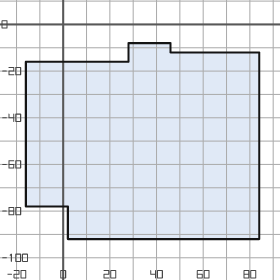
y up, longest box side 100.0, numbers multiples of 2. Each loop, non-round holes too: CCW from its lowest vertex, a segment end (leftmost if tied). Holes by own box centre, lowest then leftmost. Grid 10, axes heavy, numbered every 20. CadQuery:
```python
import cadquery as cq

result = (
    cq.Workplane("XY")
    .moveTo(2.0, -92.0)
    .lineTo(84.0, -92.0)
    .lineTo(84.0, -12.0)
    .lineTo(46.0, -12.0)
    .lineTo(46.0, -8.0)
    .lineTo(28.0, -8.0)
    .lineTo(28.0, -16.0)
    .lineTo(-16.0, -16.0)
    .lineTo(-16.0, -78.0)
    .lineTo(2.0, -78.0)
    .close()
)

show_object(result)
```